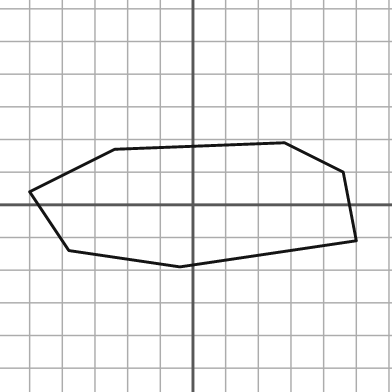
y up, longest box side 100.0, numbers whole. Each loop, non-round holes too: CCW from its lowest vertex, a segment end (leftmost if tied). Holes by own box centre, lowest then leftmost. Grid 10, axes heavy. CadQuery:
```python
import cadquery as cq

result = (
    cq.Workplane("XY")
    .moveTo(-4.0, -19.0)
    .lineTo(50.0, -11.0)
    .lineTo(46.0, 10.0)
    .lineTo(28.0, 19.0)
    .lineTo(-24.0, 17.0)
    .lineTo(-50.0, 4.0)
    .lineTo(-38.0, -14.0)
    .close()
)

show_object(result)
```